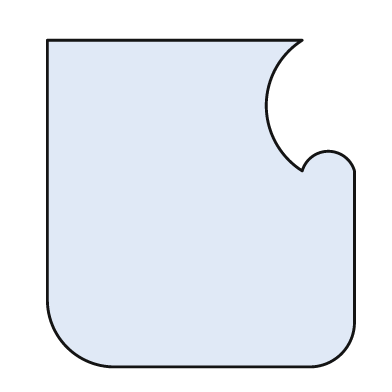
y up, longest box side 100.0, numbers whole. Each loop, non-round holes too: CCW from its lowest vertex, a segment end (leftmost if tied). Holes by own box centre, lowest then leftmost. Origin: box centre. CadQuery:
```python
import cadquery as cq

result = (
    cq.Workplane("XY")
    .moveTo(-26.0, -50.0)
    .lineTo(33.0, -50.0)
    .threePointArc((43.0, -46.0), (47.0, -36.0))
    .lineTo(47.0, 10.0)
    .threePointArc((39.0, 16.0), (31.0, 10.0))
    .threePointArc((20.0, 30.0), (31.0, 50.0))
    .lineTo(-47.0, 50.0)
    .lineTo(-47.0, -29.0)
    .threePointArc((-41.0, -44.0), (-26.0, -50.0))
    .close()
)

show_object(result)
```